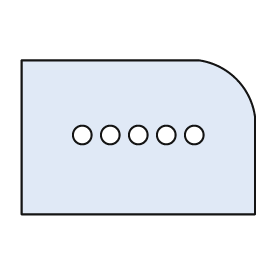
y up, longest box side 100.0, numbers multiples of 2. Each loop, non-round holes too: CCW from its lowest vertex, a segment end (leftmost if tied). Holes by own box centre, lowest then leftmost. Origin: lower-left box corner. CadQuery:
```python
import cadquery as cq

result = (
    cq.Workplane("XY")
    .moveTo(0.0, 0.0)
    .lineTo(100.0, 0.0)
    .lineTo(100.0, 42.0)
    .threePointArc((92.0, 58.0), (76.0, 66.0))
    .lineTo(0.0, 66.0)
    .close()
    .moveTo(26.0, 34.0)
    .circle(4.0)
    .moveTo(38.0, 34.0)
    .circle(4.0)
    .moveTo(50.0, 34.0)
    .circle(4.0)
    .moveTo(62.0, 34.0)
    .circle(4.0)
    .moveTo(74.0, 34.0)
    .circle(4.0)
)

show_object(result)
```